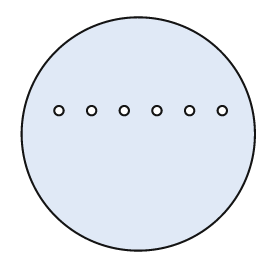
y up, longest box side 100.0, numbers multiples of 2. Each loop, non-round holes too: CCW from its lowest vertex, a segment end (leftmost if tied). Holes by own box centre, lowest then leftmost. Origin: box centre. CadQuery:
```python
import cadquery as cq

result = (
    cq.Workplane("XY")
    .moveTo(0.0, 0.0)
    .circle(50.0)
    .moveTo(-34.0, 10.0)
    .circle(2.0)
    .moveTo(-20.0, 10.0)
    .circle(2.0)
    .moveTo(-6.0, 10.0)
    .circle(2.0)
    .moveTo(8.0, 10.0)
    .circle(2.0)
    .moveTo(22.0, 10.0)
    .circle(2.0)
    .moveTo(36.0, 10.0)
    .circle(2.0)
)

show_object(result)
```